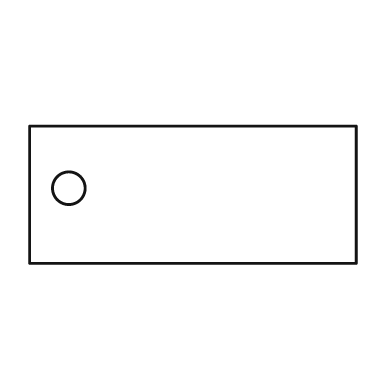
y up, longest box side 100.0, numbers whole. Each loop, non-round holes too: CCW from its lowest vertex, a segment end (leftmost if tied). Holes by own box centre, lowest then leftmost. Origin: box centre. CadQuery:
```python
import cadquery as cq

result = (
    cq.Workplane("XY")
    .moveTo(-50.0, -21.0)
    .lineTo(50.0, -21.0)
    .lineTo(50.0, 21.0)
    .lineTo(-50.0, 21.0)
    .close()
    .moveTo(-38.0, 2.0)
    .circle(5.0)
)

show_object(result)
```